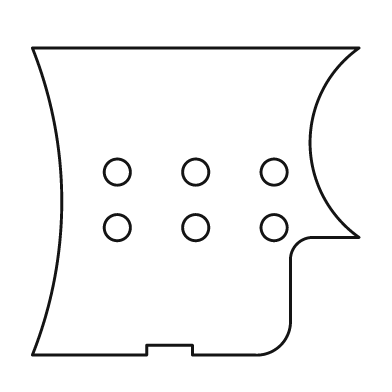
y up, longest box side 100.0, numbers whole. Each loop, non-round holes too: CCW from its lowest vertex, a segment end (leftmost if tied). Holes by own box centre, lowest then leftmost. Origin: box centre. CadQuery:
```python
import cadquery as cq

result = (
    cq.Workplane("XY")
    .moveTo(-50.0, -47.0)
    .lineTo(-15.0, -47.0)
    .lineTo(-15.0, -44.0)
    .lineTo(-1.0, -44.0)
    .lineTo(-1.0, -47.0)
    .lineTo(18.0, -47.0)
    .threePointArc((26.0, -44.0), (29.0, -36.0))
    .lineTo(29.0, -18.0)
    .threePointArc((31.0, -13.0), (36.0, -11.0))
    .lineTo(50.0, -11.0)
    .threePointArc((35.0, 18.0), (50.0, 47.0))
    .lineTo(-50.0, 47.0)
    .threePointArc((-41.0, 0.0), (-50.0, -47.0))
    .close()
    .moveTo(-24.0, -8.0)
    .circle(4.0)
    .moveTo(0.0, -8.0)
    .circle(4.0)
    .moveTo(24.0, -8.0)
    .circle(4.0)
    .moveTo(-24.0, 9.0)
    .circle(4.0)
    .moveTo(0.0, 9.0)
    .circle(4.0)
    .moveTo(24.0, 9.0)
    .circle(4.0)
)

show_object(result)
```